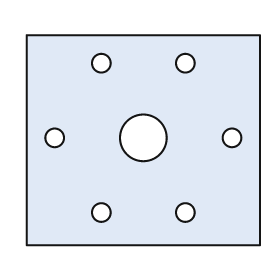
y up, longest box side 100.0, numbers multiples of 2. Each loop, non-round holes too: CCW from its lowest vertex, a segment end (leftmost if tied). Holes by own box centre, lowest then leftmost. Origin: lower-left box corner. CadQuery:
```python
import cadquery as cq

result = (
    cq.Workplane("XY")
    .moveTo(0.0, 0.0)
    .lineTo(100.0, 0.0)
    .lineTo(100.0, 90.0)
    .lineTo(0.0, 90.0)
    .close()
    .moveTo(32.0, 14.0)
    .circle(4.0)
    .moveTo(68.0, 14.0)
    .circle(4.0)
    .moveTo(12.0, 46.0)
    .circle(4.0)
    .moveTo(50.0, 46.0)
    .circle(10.0)
    .moveTo(88.0, 46.0)
    .circle(4.0)
    .moveTo(32.0, 78.0)
    .circle(4.0)
    .moveTo(68.0, 78.0)
    .circle(4.0)
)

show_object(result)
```